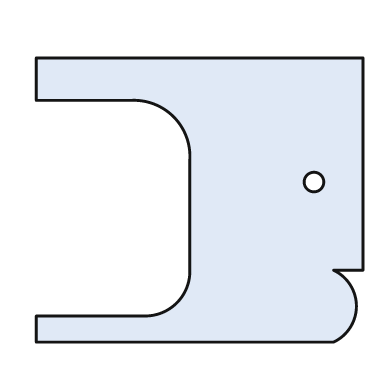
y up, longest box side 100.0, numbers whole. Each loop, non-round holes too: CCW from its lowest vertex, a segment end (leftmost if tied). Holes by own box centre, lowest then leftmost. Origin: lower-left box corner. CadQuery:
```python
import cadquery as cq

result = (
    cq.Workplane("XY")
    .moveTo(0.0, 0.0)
    .lineTo(91.0, 0.0)
    .threePointArc((98.0, 11.0), (91.0, 22.0))
    .lineTo(100.0, 22.0)
    .lineTo(100.0, 87.0)
    .lineTo(0.0, 87.0)
    .lineTo(0.0, 74.0)
    .lineTo(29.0, 74.0)
    .threePointArc((42.0, 69.0), (47.0, 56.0))
    .lineTo(47.0, 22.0)
    .threePointArc((43.0, 12.0), (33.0, 8.0))
    .lineTo(0.0, 8.0)
    .close()
    .moveTo(85.0, 49.0)
    .circle(3.0)
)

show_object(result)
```